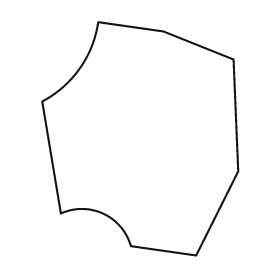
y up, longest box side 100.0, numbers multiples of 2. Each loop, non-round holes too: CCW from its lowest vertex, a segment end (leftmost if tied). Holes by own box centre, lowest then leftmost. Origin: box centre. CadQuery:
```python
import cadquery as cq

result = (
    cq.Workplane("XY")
    .moveTo(24.0, -50.0)
    .lineTo(42.0, -14.0)
    .lineTo(40.0, 34.0)
    .lineTo(10.0, 46.0)
    .lineTo(-18.0, 50.0)
    .threePointArc((-26.0, 30.0), (-42.0, 16.0))
    .lineTo(-34.0, -32.0)
    .threePointArc((-16.0, -32.0), (-4.0, -46.0))
    .close()
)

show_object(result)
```